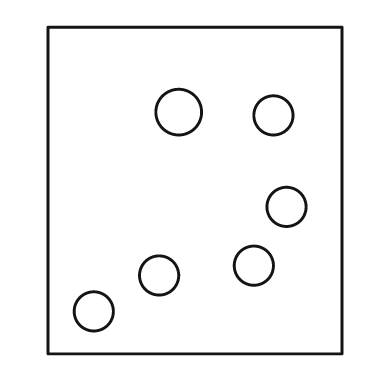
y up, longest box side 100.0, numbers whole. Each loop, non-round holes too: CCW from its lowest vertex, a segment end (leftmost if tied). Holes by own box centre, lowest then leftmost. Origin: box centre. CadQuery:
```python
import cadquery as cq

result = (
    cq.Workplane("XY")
    .moveTo(-45.0, -50.0)
    .lineTo(45.0, -50.0)
    .lineTo(45.0, 50.0)
    .lineTo(-45.0, 50.0)
    .close()
    .moveTo(-31.0, -37.0)
    .circle(6.0)
    .moveTo(-11.0, -26.0)
    .circle(6.0)
    .moveTo(18.0, -23.0)
    .circle(6.0)
    .moveTo(28.0, -5.0)
    .circle(6.0)
    .moveTo(24.0, 23.0)
    .circle(6.0)
    .moveTo(-5.0, 24.0)
    .circle(7.0)
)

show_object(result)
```